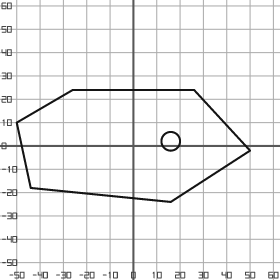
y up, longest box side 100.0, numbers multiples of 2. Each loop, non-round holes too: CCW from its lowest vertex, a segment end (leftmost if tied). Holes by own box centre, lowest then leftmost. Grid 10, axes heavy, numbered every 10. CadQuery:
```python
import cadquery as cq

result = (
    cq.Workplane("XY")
    .moveTo(16.0, -24.0)
    .lineTo(50.0, -2.0)
    .lineTo(26.0, 24.0)
    .lineTo(-26.0, 24.0)
    .lineTo(-50.0, 10.0)
    .lineTo(-44.0, -18.0)
    .close()
    .moveTo(16.0, 2.0)
    .circle(4.0)
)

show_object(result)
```